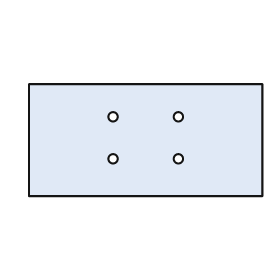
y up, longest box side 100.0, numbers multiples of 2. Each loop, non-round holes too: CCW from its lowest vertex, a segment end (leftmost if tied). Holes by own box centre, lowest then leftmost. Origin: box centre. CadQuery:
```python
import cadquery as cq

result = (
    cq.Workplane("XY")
    .moveTo(-50.0, -24.0)
    .lineTo(50.0, -24.0)
    .lineTo(50.0, 24.0)
    .lineTo(-50.0, 24.0)
    .close()
    .moveTo(-14.0, -8.0)
    .circle(2.0)
    .moveTo(14.0, -8.0)
    .circle(2.0)
    .moveTo(-14.0, 10.0)
    .circle(2.0)
    .moveTo(14.0, 10.0)
    .circle(2.0)
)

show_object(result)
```